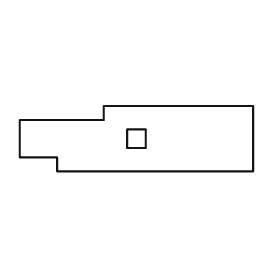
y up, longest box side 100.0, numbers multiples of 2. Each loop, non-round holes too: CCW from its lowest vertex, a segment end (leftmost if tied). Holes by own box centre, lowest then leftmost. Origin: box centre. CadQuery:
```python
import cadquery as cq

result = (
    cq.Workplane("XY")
    .moveTo(-34.0, -14.0)
    .lineTo(50.0, -14.0)
    .lineTo(50.0, 14.0)
    .lineTo(-14.0, 14.0)
    .lineTo(-14.0, 8.0)
    .lineTo(-50.0, 8.0)
    .lineTo(-50.0, -8.0)
    .lineTo(-34.0, -8.0)
    .close()
    .moveTo(-4.0, -4.0)
    .lineTo(4.0, -4.0)
    .lineTo(4.0, 4.0)
    .lineTo(-4.0, 4.0)
    .close()
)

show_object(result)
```